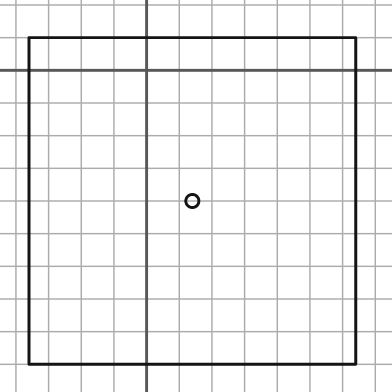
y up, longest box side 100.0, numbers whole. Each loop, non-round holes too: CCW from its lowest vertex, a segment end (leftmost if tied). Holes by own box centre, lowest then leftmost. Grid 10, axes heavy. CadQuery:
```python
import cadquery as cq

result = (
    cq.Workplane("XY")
    .moveTo(-36.0, -90.0)
    .lineTo(64.0, -90.0)
    .lineTo(64.0, 10.0)
    .lineTo(-36.0, 10.0)
    .close()
    .moveTo(14.0, -40.0)
    .circle(2.0)
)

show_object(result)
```